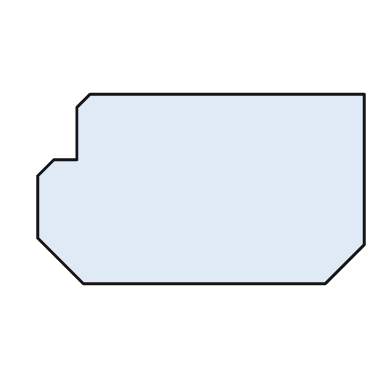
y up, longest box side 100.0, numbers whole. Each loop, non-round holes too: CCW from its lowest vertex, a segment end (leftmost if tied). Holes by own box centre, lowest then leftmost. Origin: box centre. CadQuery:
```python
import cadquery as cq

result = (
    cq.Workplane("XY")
    .moveTo(-36.0, -29.0)
    .lineTo(38.0, -29.0)
    .lineTo(50.0, -17.0)
    .lineTo(50.0, 29.0)
    .lineTo(-34.0, 29.0)
    .lineTo(-38.0, 25.0)
    .lineTo(-38.0, 9.0)
    .lineTo(-45.0, 9.0)
    .lineTo(-50.0, 4.0)
    .lineTo(-50.0, -15.0)
    .close()
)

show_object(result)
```